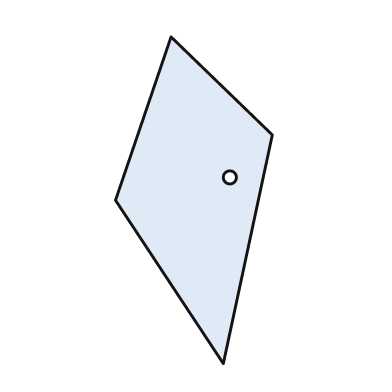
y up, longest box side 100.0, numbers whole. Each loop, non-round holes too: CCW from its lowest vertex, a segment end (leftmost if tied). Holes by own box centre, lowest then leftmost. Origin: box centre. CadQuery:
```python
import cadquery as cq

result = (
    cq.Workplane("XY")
    .moveTo(9.0, -50.0)
    .lineTo(24.0, 20.0)
    .lineTo(-7.0, 50.0)
    .lineTo(-24.0, 0.0)
    .close()
    .moveTo(11.0, 7.0)
    .circle(2.0)
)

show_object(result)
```